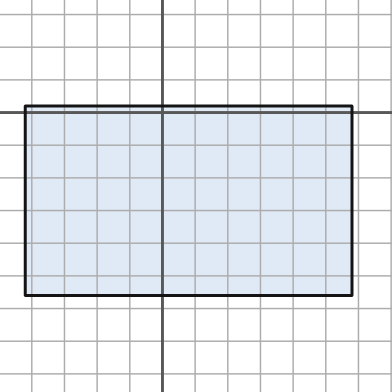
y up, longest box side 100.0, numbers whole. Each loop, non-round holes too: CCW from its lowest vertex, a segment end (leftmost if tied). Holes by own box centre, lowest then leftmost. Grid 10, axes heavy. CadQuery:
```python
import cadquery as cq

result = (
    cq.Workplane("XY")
    .moveTo(-42.0, -56.0)
    .lineTo(58.0, -56.0)
    .lineTo(58.0, 2.0)
    .lineTo(-42.0, 2.0)
    .close()
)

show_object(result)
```